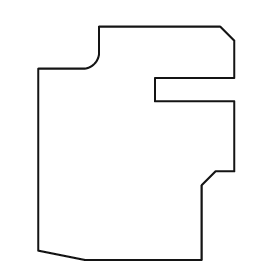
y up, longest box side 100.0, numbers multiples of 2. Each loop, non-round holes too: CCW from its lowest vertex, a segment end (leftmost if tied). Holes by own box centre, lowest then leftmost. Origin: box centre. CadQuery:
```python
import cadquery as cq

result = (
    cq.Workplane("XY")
    .moveTo(-22.0, -50.0)
    .lineTo(28.0, -50.0)
    .lineTo(28.0, -18.0)
    .lineTo(34.0, -12.0)
    .lineTo(42.0, -12.0)
    .lineTo(42.0, 18.0)
    .lineTo(8.0, 18.0)
    .lineTo(8.0, 28.0)
    .lineTo(42.0, 28.0)
    .lineTo(42.0, 44.0)
    .lineTo(36.0, 50.0)
    .lineTo(-16.0, 50.0)
    .lineTo(-16.0, 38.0)
    .threePointArc((-18.0, 34.0), (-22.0, 32.0))
    .lineTo(-42.0, 32.0)
    .lineTo(-42.0, -46.0)
    .close()
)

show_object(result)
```